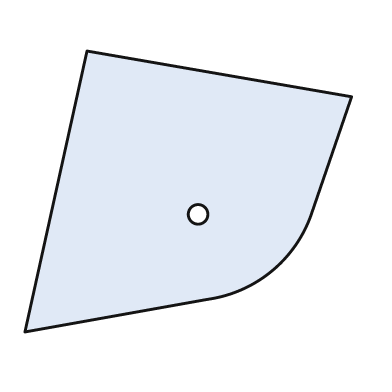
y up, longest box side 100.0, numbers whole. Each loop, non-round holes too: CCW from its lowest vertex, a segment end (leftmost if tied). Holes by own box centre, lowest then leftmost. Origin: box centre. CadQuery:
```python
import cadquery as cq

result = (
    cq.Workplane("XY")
    .moveTo(-50.0, -43.0)
    .lineTo(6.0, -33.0)
    .threePointArc((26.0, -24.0), (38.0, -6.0))
    .lineTo(50.0, 29.0)
    .lineTo(-31.0, 43.0)
    .close()
    .moveTo(3.0, -7.0)
    .circle(3.0)
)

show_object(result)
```